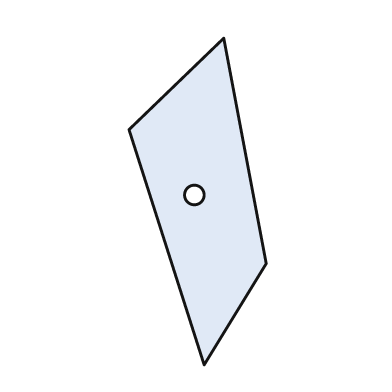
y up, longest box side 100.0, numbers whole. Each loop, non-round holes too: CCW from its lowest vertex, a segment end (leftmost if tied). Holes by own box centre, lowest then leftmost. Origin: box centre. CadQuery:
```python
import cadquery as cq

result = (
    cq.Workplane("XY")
    .moveTo(2.0, -50.0)
    .lineTo(21.0, -19.0)
    .lineTo(8.0, 50.0)
    .lineTo(-21.0, 22.0)
    .close()
    .moveTo(-1.0, 2.0)
    .circle(3.0)
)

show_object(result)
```